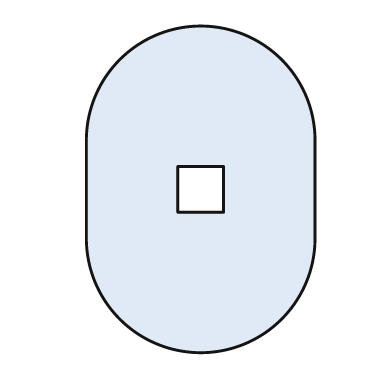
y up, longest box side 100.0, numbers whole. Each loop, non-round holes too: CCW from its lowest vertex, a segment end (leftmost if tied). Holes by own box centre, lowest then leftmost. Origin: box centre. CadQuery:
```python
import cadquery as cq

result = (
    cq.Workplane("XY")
    .moveTo(-35.0, -15.0)
    .threePointArc((0.0, -50.0), (35.0, -15.0))
    .lineTo(35.0, 15.0)
    .threePointArc((0.0, 50.0), (-35.0, 15.0))
    .close()
    .moveTo(-7.0, -7.0)
    .lineTo(7.0, -7.0)
    .lineTo(7.0, 7.0)
    .lineTo(-7.0, 7.0)
    .close()
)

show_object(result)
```